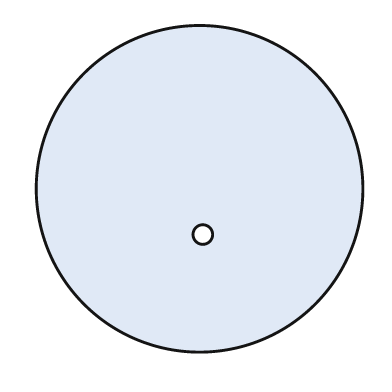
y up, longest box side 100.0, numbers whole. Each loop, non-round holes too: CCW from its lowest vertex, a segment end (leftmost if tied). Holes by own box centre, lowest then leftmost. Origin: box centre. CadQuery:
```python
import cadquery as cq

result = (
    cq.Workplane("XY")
    .moveTo(0.0, 0.0)
    .circle(50.0)
    .moveTo(1.0, -14.0)
    .circle(3.0)
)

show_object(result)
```